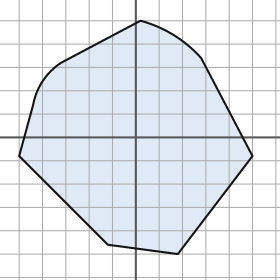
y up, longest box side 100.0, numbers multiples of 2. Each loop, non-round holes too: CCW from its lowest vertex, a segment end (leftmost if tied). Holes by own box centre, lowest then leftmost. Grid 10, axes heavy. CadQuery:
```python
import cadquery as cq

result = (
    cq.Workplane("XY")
    .moveTo(18.0, -50.0)
    .lineTo(50.0, -8.0)
    .lineTo(28.0, 34.0)
    .threePointArc((16.0, 44.0), (2.0, 50.0))
    .lineTo(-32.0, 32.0)
    .threePointArc((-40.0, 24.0), (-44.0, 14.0))
    .lineTo(-50.0, -8.0)
    .lineTo(-12.0, -46.0)
    .close()
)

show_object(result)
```